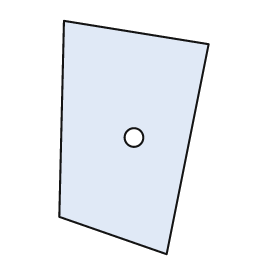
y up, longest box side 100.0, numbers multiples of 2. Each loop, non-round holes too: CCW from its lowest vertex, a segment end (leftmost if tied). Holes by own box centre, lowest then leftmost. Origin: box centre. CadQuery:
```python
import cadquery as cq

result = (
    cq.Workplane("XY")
    .moveTo(14.0, -50.0)
    .lineTo(32.0, 40.0)
    .lineTo(-30.0, 50.0)
    .lineTo(-32.0, -34.0)
    .close()
    .moveTo(0.0, 0.0)
    .circle(4.0)
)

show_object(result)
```